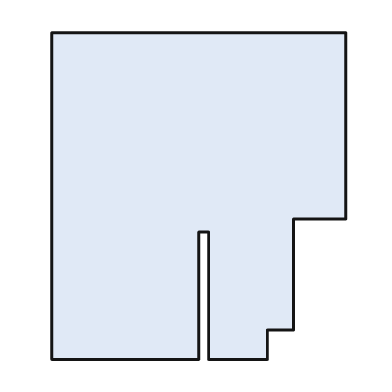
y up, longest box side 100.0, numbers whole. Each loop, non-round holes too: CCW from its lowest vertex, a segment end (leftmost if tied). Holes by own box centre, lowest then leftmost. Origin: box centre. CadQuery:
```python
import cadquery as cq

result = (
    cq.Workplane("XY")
    .moveTo(-45.0, -50.0)
    .lineTo(0.0, -50.0)
    .lineTo(0.0, -11.0)
    .lineTo(3.0, -11.0)
    .lineTo(3.0, -50.0)
    .lineTo(21.0, -50.0)
    .lineTo(21.0, -41.0)
    .lineTo(29.0, -41.0)
    .lineTo(29.0, -7.0)
    .lineTo(45.0, -7.0)
    .lineTo(45.0, 50.0)
    .lineTo(-45.0, 50.0)
    .close()
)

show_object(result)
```